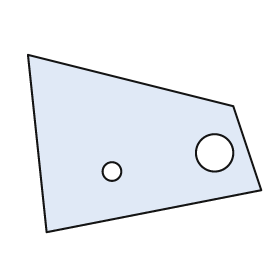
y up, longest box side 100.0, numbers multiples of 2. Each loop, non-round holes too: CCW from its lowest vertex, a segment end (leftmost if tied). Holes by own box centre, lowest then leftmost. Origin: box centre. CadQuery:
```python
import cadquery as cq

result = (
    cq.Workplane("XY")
    .moveTo(-42.0, -38.0)
    .lineTo(50.0, -20.0)
    .lineTo(38.0, 16.0)
    .lineTo(-50.0, 38.0)
    .close()
    .moveTo(-14.0, -12.0)
    .circle(4.0)
    .moveTo(30.0, -4.0)
    .circle(8.0)
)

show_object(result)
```